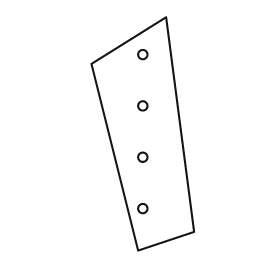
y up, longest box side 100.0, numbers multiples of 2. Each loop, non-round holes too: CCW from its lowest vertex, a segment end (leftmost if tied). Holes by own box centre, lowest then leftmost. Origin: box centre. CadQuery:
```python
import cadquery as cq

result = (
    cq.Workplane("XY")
    .moveTo(-2.0, -50.0)
    .lineTo(22.0, -42.0)
    .lineTo(10.0, 50.0)
    .lineTo(-22.0, 30.0)
    .close()
    .moveTo(0.0, -32.0)
    .circle(2.0)
    .moveTo(0.0, -10.0)
    .circle(2.0)
    .moveTo(0.0, 12.0)
    .circle(2.0)
    .moveTo(0.0, 34.0)
    .circle(2.0)
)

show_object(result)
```